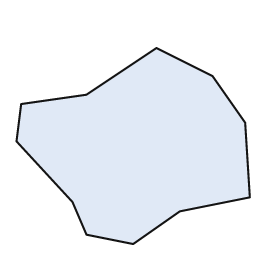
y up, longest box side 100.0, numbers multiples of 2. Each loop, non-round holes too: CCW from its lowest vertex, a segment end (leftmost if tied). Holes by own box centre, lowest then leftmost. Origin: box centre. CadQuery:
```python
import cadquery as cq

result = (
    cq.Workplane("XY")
    .moveTo(0.0, -42.0)
    .lineTo(20.0, -28.0)
    .lineTo(50.0, -22.0)
    .lineTo(48.0, 10.0)
    .lineTo(34.0, 30.0)
    .lineTo(10.0, 42.0)
    .lineTo(-20.0, 22.0)
    .lineTo(-48.0, 18.0)
    .lineTo(-50.0, 2.0)
    .lineTo(-26.0, -24.0)
    .lineTo(-20.0, -38.0)
    .close()
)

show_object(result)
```